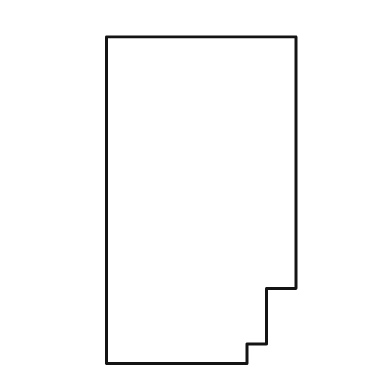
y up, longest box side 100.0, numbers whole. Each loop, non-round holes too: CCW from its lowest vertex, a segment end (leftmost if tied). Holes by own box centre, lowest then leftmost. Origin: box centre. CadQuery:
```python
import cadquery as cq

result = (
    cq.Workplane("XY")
    .moveTo(-29.0, -50.0)
    .lineTo(14.0, -50.0)
    .lineTo(14.0, -44.0)
    .lineTo(20.0, -44.0)
    .lineTo(20.0, -27.0)
    .lineTo(29.0, -27.0)
    .lineTo(29.0, 50.0)
    .lineTo(-29.0, 50.0)
    .close()
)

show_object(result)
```